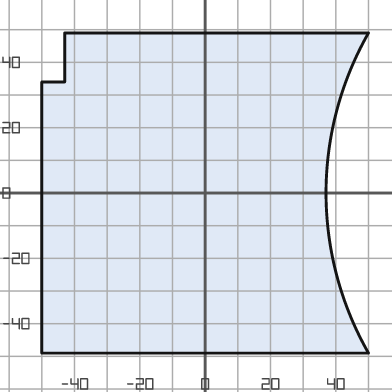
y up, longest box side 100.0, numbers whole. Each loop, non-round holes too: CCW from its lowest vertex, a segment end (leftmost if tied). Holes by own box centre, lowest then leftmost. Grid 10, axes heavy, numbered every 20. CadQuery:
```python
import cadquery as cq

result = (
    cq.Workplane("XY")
    .moveTo(-50.0, -49.0)
    .lineTo(50.0, -49.0)
    .threePointArc((37.0, 0.0), (50.0, 49.0))
    .lineTo(-43.0, 49.0)
    .lineTo(-43.0, 34.0)
    .lineTo(-50.0, 34.0)
    .close()
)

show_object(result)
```